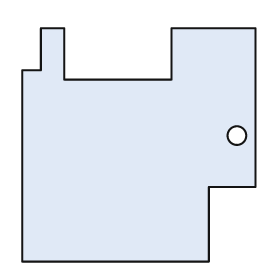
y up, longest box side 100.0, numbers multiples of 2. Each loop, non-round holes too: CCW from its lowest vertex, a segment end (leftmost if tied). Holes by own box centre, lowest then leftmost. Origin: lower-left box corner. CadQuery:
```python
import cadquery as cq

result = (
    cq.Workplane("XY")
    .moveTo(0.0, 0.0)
    .lineTo(80.0, 0.0)
    .lineTo(80.0, 32.0)
    .lineTo(100.0, 32.0)
    .lineTo(100.0, 100.0)
    .lineTo(64.0, 100.0)
    .lineTo(64.0, 78.0)
    .lineTo(18.0, 78.0)
    .lineTo(18.0, 100.0)
    .lineTo(8.0, 100.0)
    .lineTo(8.0, 82.0)
    .lineTo(0.0, 82.0)
    .close()
    .moveTo(92.0, 54.0)
    .circle(4.0)
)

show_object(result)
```